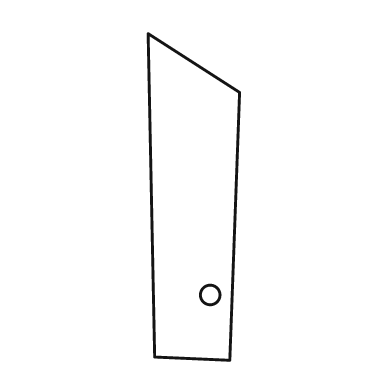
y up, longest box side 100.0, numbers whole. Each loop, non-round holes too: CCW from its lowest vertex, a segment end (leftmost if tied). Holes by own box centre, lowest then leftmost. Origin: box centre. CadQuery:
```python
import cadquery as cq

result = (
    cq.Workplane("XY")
    .moveTo(11.0, -50.0)
    .lineTo(14.0, 32.0)
    .lineTo(-14.0, 50.0)
    .lineTo(-12.0, -49.0)
    .close()
    .moveTo(5.0, -30.0)
    .circle(3.0)
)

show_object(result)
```